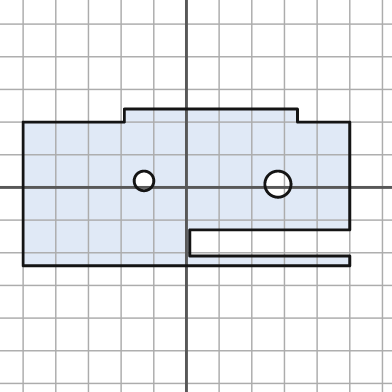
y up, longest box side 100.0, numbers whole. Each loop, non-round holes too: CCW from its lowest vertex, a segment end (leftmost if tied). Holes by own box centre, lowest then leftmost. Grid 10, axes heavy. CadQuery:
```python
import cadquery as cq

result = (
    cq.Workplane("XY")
    .moveTo(-50.0, -24.0)
    .lineTo(50.0, -24.0)
    .lineTo(50.0, -21.0)
    .lineTo(1.0, -21.0)
    .lineTo(1.0, -13.0)
    .lineTo(50.0, -13.0)
    .lineTo(50.0, 20.0)
    .lineTo(34.0, 20.0)
    .lineTo(34.0, 24.0)
    .lineTo(-19.0, 24.0)
    .lineTo(-19.0, 20.0)
    .lineTo(-50.0, 20.0)
    .close()
    .moveTo(28.0, 1.0)
    .circle(4.0)
    .moveTo(-13.0, 2.0)
    .circle(3.0)
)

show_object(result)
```